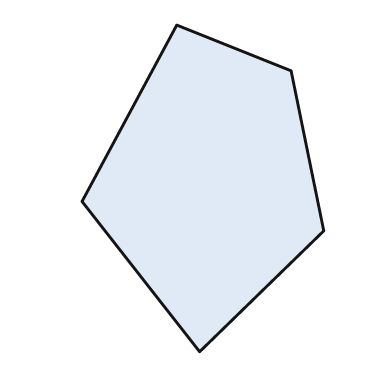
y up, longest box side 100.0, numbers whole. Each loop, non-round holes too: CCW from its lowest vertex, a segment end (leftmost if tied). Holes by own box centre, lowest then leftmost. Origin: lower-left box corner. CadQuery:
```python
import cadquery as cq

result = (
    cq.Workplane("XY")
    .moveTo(36.0, 0.0)
    .lineTo(74.0, 37.0)
    .lineTo(64.0, 86.0)
    .lineTo(29.0, 100.0)
    .lineTo(0.0, 46.0)
    .close()
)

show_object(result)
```